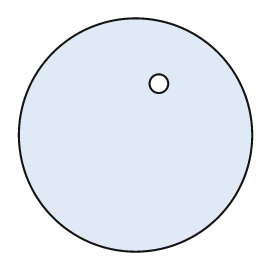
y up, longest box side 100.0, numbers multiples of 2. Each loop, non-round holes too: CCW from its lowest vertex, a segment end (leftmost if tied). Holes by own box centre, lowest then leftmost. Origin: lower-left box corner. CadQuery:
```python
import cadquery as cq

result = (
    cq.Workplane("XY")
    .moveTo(50.0, 50.0)
    .circle(50.0)
    .moveTo(60.0, 72.0)
    .circle(4.0)
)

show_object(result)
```